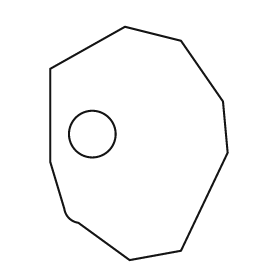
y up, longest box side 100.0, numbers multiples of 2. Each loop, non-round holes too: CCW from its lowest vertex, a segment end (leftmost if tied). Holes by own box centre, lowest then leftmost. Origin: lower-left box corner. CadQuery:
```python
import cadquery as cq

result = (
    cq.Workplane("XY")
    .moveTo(34.0, 0.0)
    .lineTo(56.0, 4.0)
    .lineTo(76.0, 46.0)
    .lineTo(74.0, 68.0)
    .lineTo(56.0, 94.0)
    .lineTo(32.0, 100.0)
    .lineTo(0.0, 82.0)
    .lineTo(0.0, 42.0)
    .lineTo(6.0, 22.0)
    .threePointArc((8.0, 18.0), (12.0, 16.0))
    .close()
    .moveTo(18.0, 54.0)
    .circle(10.0)
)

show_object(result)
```